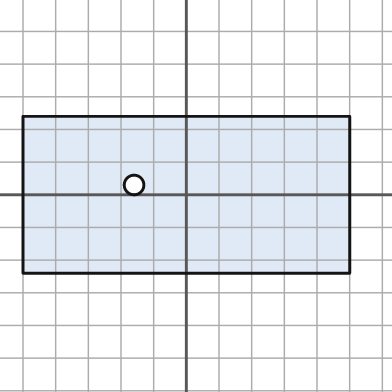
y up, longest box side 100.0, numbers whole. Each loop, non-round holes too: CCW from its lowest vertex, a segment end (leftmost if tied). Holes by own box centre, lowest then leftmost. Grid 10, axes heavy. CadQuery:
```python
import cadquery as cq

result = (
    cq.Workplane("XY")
    .moveTo(-50.0, -24.0)
    .lineTo(50.0, -24.0)
    .lineTo(50.0, 24.0)
    .lineTo(-50.0, 24.0)
    .close()
    .moveTo(-16.0, 3.0)
    .circle(3.0)
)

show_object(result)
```